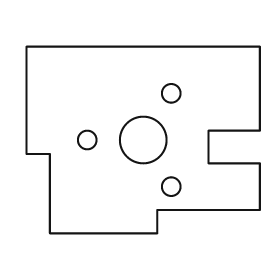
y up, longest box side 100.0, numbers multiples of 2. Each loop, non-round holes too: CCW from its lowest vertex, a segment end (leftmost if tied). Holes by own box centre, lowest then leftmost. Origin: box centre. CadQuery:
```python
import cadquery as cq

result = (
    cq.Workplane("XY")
    .moveTo(-40.0, -40.0)
    .lineTo(6.0, -40.0)
    .lineTo(6.0, -30.0)
    .lineTo(50.0, -30.0)
    .lineTo(50.0, -10.0)
    .lineTo(28.0, -10.0)
    .lineTo(28.0, 4.0)
    .lineTo(50.0, 4.0)
    .lineTo(50.0, 40.0)
    .lineTo(-50.0, 40.0)
    .lineTo(-50.0, -6.0)
    .lineTo(-40.0, -6.0)
    .close()
    .moveTo(12.0, -20.0)
    .circle(4.0)
    .moveTo(-24.0, 0.0)
    .circle(4.0)
    .moveTo(0.0, 0.0)
    .circle(10.0)
    .moveTo(12.0, 20.0)
    .circle(4.0)
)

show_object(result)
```